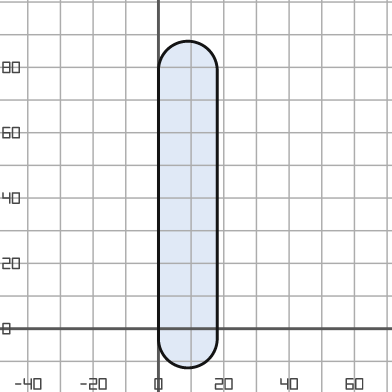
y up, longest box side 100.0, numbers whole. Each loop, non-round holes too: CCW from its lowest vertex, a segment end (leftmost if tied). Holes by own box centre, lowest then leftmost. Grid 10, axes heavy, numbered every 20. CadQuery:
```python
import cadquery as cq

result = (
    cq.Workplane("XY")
    .moveTo(0.0, -3.0)
    .threePointArc((9.0, -12.0), (18.0, -3.0))
    .lineTo(18.0, 79.0)
    .threePointArc((9.0, 88.0), (0.0, 79.0))
    .close()
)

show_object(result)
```